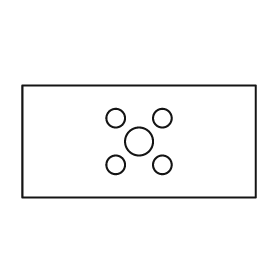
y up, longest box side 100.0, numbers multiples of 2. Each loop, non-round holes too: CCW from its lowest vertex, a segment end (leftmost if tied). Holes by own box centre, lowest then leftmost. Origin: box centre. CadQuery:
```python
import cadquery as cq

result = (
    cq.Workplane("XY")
    .moveTo(-50.0, -24.0)
    .lineTo(50.0, -24.0)
    .lineTo(50.0, 24.0)
    .lineTo(-50.0, 24.0)
    .close()
    .moveTo(-10.0, -10.0)
    .circle(4.0)
    .moveTo(10.0, -10.0)
    .circle(4.0)
    .moveTo(0.0, 0.0)
    .circle(6.0)
    .moveTo(-10.0, 10.0)
    .circle(4.0)
    .moveTo(10.0, 10.0)
    .circle(4.0)
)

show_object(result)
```